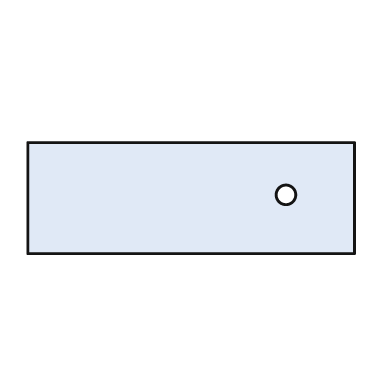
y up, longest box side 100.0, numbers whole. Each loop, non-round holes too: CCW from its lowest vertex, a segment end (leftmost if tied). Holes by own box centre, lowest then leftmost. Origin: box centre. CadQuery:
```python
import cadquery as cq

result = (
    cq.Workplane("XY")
    .moveTo(-50.0, -17.0)
    .lineTo(50.0, -17.0)
    .lineTo(50.0, 17.0)
    .lineTo(-50.0, 17.0)
    .close()
    .moveTo(29.0, 1.0)
    .circle(3.0)
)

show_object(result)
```